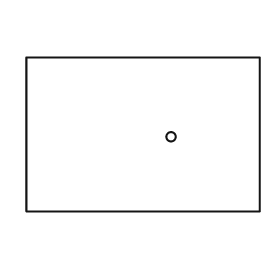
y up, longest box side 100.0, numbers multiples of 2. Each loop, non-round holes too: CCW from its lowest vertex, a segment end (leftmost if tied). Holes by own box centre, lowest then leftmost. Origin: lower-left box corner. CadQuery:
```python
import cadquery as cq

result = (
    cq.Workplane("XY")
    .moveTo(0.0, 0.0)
    .lineTo(100.0, 0.0)
    .lineTo(100.0, 66.0)
    .lineTo(0.0, 66.0)
    .close()
    .moveTo(62.0, 32.0)
    .circle(2.0)
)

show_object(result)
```